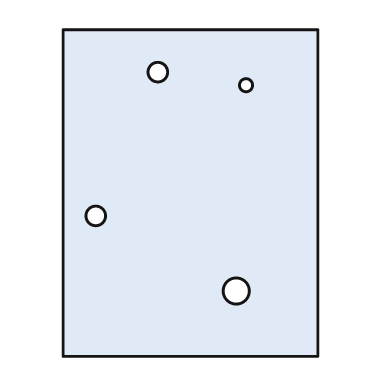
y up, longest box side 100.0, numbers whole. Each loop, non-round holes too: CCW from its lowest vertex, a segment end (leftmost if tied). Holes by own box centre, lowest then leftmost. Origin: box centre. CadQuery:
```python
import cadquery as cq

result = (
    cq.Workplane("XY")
    .moveTo(-39.0, -50.0)
    .lineTo(39.0, -50.0)
    .lineTo(39.0, 50.0)
    .lineTo(-39.0, 50.0)
    .close()
    .moveTo(14.0, -30.0)
    .circle(4.0)
    .moveTo(-29.0, -7.0)
    .circle(3.0)
    .moveTo(17.0, 33.0)
    .circle(2.0)
    .moveTo(-10.0, 37.0)
    .circle(3.0)
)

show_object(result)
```